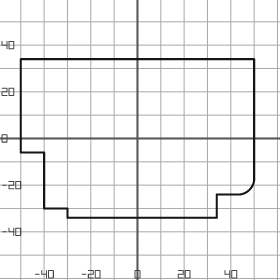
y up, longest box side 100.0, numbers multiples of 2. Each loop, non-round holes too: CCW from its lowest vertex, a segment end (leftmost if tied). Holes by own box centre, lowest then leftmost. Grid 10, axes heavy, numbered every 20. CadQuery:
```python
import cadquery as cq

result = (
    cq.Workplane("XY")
    .moveTo(-30.0, -34.0)
    .lineTo(34.0, -34.0)
    .lineTo(34.0, -24.0)
    .lineTo(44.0, -24.0)
    .threePointArc((48.0, -22.0), (50.0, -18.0))
    .lineTo(50.0, 34.0)
    .lineTo(-50.0, 34.0)
    .lineTo(-50.0, -6.0)
    .lineTo(-40.0, -6.0)
    .lineTo(-40.0, -30.0)
    .lineTo(-30.0, -30.0)
    .close()
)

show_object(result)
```